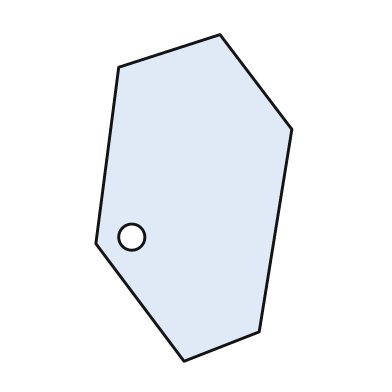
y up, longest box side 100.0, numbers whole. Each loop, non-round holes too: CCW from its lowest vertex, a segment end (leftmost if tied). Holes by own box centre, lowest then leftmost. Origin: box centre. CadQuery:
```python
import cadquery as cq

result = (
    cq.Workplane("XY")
    .moveTo(-3.0, -50.0)
    .lineTo(20.0, -41.0)
    .lineTo(30.0, 21.0)
    .lineTo(8.0, 50.0)
    .lineTo(-23.0, 40.0)
    .lineTo(-30.0, -14.0)
    .close()
    .moveTo(-19.0, -12.0)
    .circle(4.0)
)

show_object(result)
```